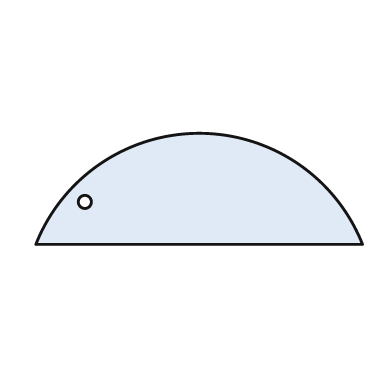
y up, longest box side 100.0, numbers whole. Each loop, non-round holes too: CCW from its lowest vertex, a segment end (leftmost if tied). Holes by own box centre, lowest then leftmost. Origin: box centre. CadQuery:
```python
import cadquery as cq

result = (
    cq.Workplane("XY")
    .moveTo(-50.0, -17.0)
    .lineTo(50.0, -17.0)
    .threePointArc((0.0, 17.0), (-50.0, -17.0))
    .close()
    .moveTo(-35.0, -4.0)
    .circle(2.0)
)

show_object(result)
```